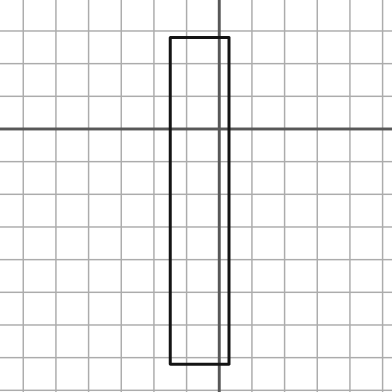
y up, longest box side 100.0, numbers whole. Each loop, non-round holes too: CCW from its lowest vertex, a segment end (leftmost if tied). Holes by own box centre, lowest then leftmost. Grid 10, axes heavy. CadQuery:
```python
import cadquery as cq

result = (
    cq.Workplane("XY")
    .moveTo(-15.0, -72.0)
    .lineTo(3.0, -72.0)
    .lineTo(3.0, 28.0)
    .lineTo(-15.0, 28.0)
    .close()
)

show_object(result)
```